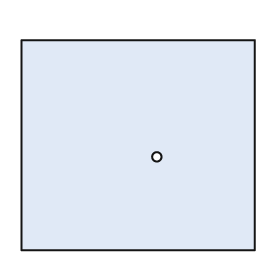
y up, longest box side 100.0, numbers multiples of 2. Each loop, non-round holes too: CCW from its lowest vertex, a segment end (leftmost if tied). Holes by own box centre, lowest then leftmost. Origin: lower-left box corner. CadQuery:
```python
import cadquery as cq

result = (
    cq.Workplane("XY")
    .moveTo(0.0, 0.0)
    .lineTo(100.0, 0.0)
    .lineTo(100.0, 90.0)
    .lineTo(0.0, 90.0)
    .close()
    .moveTo(58.0, 40.0)
    .circle(2.0)
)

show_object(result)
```